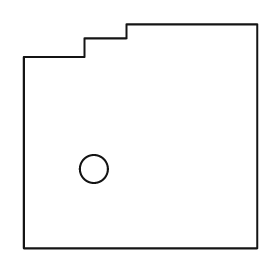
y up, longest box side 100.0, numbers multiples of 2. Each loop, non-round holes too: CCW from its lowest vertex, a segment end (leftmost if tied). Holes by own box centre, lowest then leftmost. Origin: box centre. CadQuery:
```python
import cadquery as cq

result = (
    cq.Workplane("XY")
    .moveTo(-50.0, -48.0)
    .lineTo(50.0, -48.0)
    .lineTo(50.0, 48.0)
    .lineTo(-6.0, 48.0)
    .lineTo(-6.0, 42.0)
    .lineTo(-24.0, 42.0)
    .lineTo(-24.0, 34.0)
    .lineTo(-50.0, 34.0)
    .close()
    .moveTo(-20.0, -14.0)
    .circle(6.0)
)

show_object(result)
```